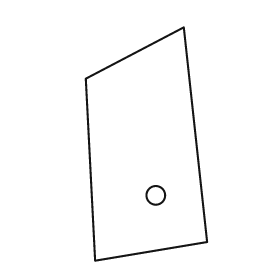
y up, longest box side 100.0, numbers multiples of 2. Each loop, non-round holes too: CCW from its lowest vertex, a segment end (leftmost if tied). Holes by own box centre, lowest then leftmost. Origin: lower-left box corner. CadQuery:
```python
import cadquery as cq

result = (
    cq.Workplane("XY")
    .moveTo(4.0, 0.0)
    .lineTo(52.0, 8.0)
    .lineTo(42.0, 100.0)
    .lineTo(0.0, 78.0)
    .close()
    .moveTo(30.0, 28.0)
    .circle(4.0)
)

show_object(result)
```